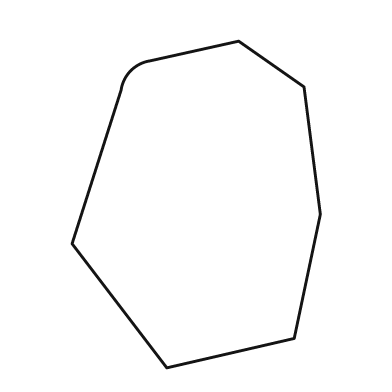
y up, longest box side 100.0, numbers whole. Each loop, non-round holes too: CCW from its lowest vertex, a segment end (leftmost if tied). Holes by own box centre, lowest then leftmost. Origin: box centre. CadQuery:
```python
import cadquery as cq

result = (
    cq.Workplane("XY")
    .moveTo(-9.0, -50.0)
    .lineTo(30.0, -41.0)
    .lineTo(38.0, -3.0)
    .lineTo(33.0, 36.0)
    .lineTo(13.0, 50.0)
    .lineTo(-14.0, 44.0)
    .threePointArc((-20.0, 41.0), (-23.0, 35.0))
    .lineTo(-38.0, -12.0)
    .close()
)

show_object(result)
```